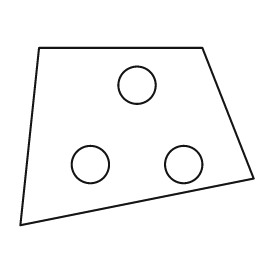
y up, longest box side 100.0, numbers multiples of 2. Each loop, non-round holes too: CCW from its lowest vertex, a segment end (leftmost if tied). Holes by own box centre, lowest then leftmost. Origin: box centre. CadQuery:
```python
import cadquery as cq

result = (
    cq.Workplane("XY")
    .moveTo(-50.0, -38.0)
    .lineTo(50.0, -18.0)
    .lineTo(28.0, 38.0)
    .lineTo(-42.0, 38.0)
    .close()
    .moveTo(-20.0, -12.0)
    .circle(8.0)
    .moveTo(20.0, -12.0)
    .circle(8.0)
    .moveTo(0.0, 22.0)
    .circle(8.0)
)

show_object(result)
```